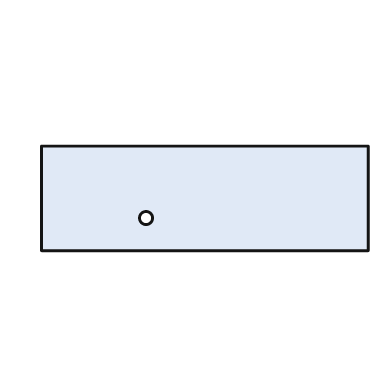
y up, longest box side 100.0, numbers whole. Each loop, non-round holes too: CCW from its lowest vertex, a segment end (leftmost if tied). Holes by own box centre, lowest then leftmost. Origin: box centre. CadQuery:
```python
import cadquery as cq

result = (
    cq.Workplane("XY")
    .moveTo(-50.0, -16.0)
    .lineTo(50.0, -16.0)
    .lineTo(50.0, 16.0)
    .lineTo(-50.0, 16.0)
    .close()
    .moveTo(-18.0, -6.0)
    .circle(2.0)
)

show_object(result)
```